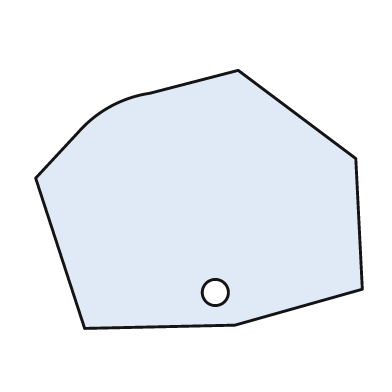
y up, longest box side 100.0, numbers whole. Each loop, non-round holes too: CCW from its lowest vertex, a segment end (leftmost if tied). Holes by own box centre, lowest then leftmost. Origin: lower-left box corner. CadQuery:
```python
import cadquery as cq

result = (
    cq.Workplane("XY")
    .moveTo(15.0, 0.0)
    .lineTo(61.0, 1.0)
    .lineTo(100.0, 12.0)
    .lineTo(98.0, 52.0)
    .lineTo(62.0, 79.0)
    .lineTo(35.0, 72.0)
    .threePointArc((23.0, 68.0), (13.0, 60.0))
    .lineTo(0.0, 46.0)
    .close()
    .moveTo(55.0, 11.0)
    .circle(4.0)
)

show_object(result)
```